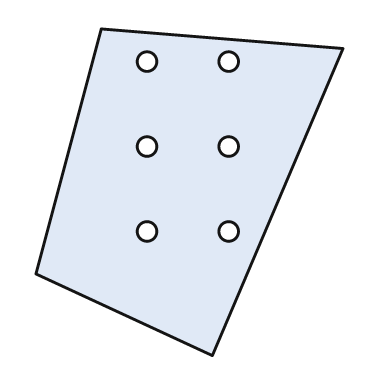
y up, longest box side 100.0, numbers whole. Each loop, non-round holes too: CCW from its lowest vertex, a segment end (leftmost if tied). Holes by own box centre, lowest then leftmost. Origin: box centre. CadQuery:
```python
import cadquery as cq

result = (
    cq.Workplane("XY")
    .moveTo(7.0, -50.0)
    .lineTo(47.0, 44.0)
    .lineTo(-27.0, 50.0)
    .lineTo(-47.0, -25.0)
    .close()
    .moveTo(-13.0, -12.0)
    .circle(3.0)
    .moveTo(12.0, -12.0)
    .circle(3.0)
    .moveTo(-13.0, 14.0)
    .circle(3.0)
    .moveTo(12.0, 14.0)
    .circle(3.0)
    .moveTo(-13.0, 40.0)
    .circle(3.0)
    .moveTo(12.0, 40.0)
    .circle(3.0)
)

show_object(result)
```